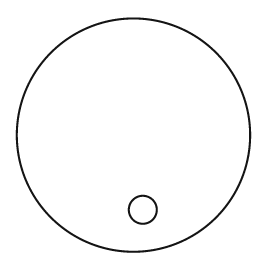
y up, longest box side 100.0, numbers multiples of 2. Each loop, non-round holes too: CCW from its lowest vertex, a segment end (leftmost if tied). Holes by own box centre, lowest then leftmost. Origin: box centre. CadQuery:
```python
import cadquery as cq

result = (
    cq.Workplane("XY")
    .moveTo(0.0, 0.0)
    .circle(50.0)
    .moveTo(4.0, -32.0)
    .circle(6.0)
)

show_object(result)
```